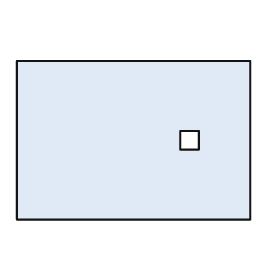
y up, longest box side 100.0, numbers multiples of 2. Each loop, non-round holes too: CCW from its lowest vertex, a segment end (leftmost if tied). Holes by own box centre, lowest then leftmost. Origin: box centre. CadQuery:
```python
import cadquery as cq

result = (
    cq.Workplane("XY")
    .moveTo(-50.0, -34.0)
    .lineTo(50.0, -34.0)
    .lineTo(50.0, 34.0)
    .lineTo(-50.0, 34.0)
    .close()
    .moveTo(20.0, -4.0)
    .lineTo(28.0, -4.0)
    .lineTo(28.0, 4.0)
    .lineTo(20.0, 4.0)
    .close()
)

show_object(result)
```